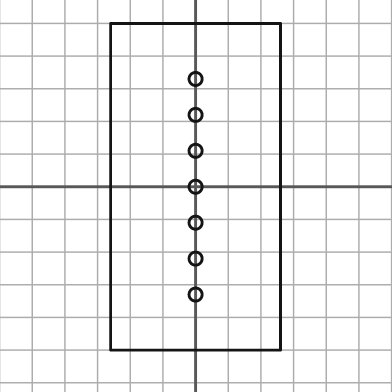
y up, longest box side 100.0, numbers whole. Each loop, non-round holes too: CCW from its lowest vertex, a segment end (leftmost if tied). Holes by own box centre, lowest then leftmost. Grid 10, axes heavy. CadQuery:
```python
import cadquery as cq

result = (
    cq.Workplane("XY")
    .moveTo(-26.0, -50.0)
    .lineTo(26.0, -50.0)
    .lineTo(26.0, 50.0)
    .lineTo(-26.0, 50.0)
    .close()
    .moveTo(0.0, -33.0)
    .circle(2.0)
    .moveTo(0.0, -22.0)
    .circle(2.0)
    .moveTo(0.0, -11.0)
    .circle(2.0)
    .moveTo(0.0, 0.0)
    .circle(2.0)
    .moveTo(0.0, 11.0)
    .circle(2.0)
    .moveTo(0.0, 22.0)
    .circle(2.0)
    .moveTo(0.0, 33.0)
    .circle(2.0)
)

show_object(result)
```